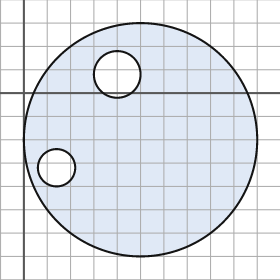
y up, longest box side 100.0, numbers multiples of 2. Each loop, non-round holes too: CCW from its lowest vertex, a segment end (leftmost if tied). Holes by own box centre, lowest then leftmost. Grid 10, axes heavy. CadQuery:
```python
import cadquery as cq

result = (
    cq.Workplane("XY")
    .moveTo(50.0, -20.0)
    .circle(50.0)
    .moveTo(14.0, -32.0)
    .circle(8.0)
    .moveTo(40.0, 8.0)
    .circle(10.0)
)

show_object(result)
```